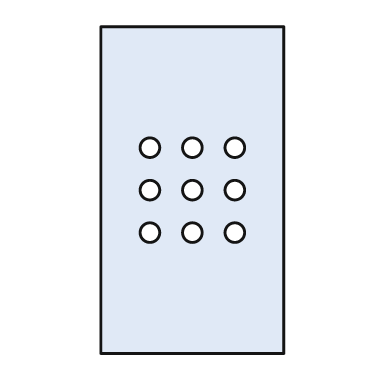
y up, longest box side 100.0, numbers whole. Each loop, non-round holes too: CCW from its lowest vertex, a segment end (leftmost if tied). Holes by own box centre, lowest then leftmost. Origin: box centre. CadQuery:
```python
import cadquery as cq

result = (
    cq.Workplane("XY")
    .moveTo(-28.0, -50.0)
    .lineTo(28.0, -50.0)
    .lineTo(28.0, 50.0)
    .lineTo(-28.0, 50.0)
    .close()
    .moveTo(-13.0, -13.0)
    .circle(3.0)
    .moveTo(0.0, -13.0)
    .circle(3.0)
    .moveTo(13.0, -13.0)
    .circle(3.0)
    .moveTo(-13.0, 0.0)
    .circle(3.0)
    .moveTo(0.0, 0.0)
    .circle(3.0)
    .moveTo(13.0, 0.0)
    .circle(3.0)
    .moveTo(-13.0, 13.0)
    .circle(3.0)
    .moveTo(0.0, 13.0)
    .circle(3.0)
    .moveTo(13.0, 13.0)
    .circle(3.0)
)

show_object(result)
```